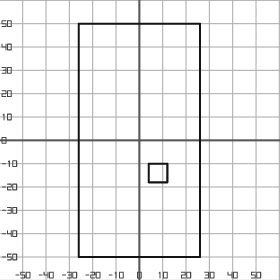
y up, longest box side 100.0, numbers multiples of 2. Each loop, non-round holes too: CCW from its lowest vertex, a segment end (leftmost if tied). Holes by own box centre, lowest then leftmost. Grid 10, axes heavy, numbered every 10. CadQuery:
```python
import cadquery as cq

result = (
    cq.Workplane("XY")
    .moveTo(-26.0, -50.0)
    .lineTo(26.0, -50.0)
    .lineTo(26.0, 50.0)
    .lineTo(-26.0, 50.0)
    .close()
    .moveTo(4.0, -18.0)
    .lineTo(12.0, -18.0)
    .lineTo(12.0, -10.0)
    .lineTo(4.0, -10.0)
    .close()
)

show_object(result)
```